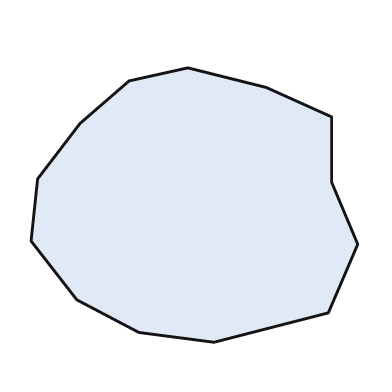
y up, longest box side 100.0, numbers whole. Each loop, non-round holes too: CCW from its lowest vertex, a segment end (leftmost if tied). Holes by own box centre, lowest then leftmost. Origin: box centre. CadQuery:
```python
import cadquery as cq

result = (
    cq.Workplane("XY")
    .moveTo(6.0, -42.0)
    .lineTo(41.0, -33.0)
    .lineTo(50.0, -12.0)
    .lineTo(42.0, 7.0)
    .lineTo(42.0, 27.0)
    .lineTo(22.0, 36.0)
    .lineTo(-2.0, 42.0)
    .lineTo(-20.0, 38.0)
    .lineTo(-35.0, 25.0)
    .lineTo(-48.0, 8.0)
    .lineTo(-50.0, -11.0)
    .lineTo(-36.0, -29.0)
    .lineTo(-17.0, -39.0)
    .close()
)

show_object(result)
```